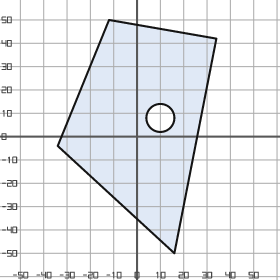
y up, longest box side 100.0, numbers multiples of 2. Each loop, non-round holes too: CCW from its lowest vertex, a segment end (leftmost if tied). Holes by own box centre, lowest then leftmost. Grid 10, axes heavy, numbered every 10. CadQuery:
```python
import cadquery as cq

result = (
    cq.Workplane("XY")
    .moveTo(16.0, -50.0)
    .lineTo(34.0, 42.0)
    .lineTo(-12.0, 50.0)
    .lineTo(-34.0, -4.0)
    .close()
    .moveTo(10.0, 8.0)
    .circle(6.0)
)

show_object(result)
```